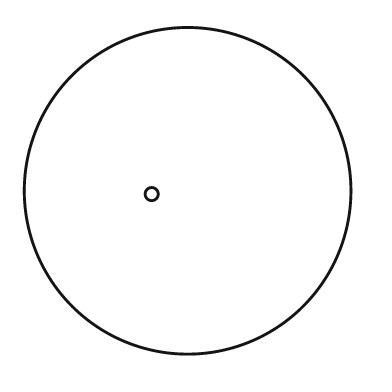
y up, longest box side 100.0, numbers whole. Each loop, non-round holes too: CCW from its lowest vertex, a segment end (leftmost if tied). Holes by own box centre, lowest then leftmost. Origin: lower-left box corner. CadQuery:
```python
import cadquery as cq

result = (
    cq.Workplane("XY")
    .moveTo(50.0, 50.0)
    .circle(50.0)
    .moveTo(39.0, 49.0)
    .circle(2.0)
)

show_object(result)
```